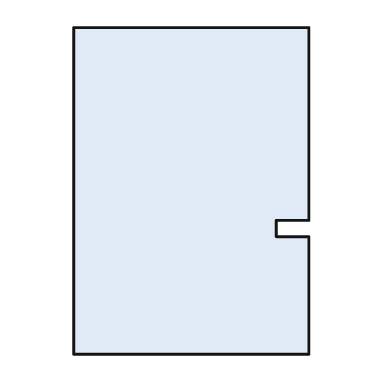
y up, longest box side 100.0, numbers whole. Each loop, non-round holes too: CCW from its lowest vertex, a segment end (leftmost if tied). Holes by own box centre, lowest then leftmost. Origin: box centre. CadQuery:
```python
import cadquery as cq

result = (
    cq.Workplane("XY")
    .moveTo(-36.0, -50.0)
    .lineTo(36.0, -50.0)
    .lineTo(36.0, -14.0)
    .lineTo(26.0, -14.0)
    .lineTo(26.0, -9.0)
    .lineTo(36.0, -9.0)
    .lineTo(36.0, 50.0)
    .lineTo(-36.0, 50.0)
    .close()
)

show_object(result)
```